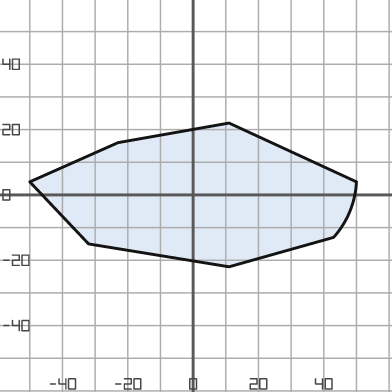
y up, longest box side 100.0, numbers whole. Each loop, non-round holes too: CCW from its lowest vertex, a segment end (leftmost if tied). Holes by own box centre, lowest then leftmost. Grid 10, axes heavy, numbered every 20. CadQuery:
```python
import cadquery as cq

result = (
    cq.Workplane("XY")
    .moveTo(11.0, -22.0)
    .lineTo(43.0, -13.0)
    .threePointArc((48.0, -5.0), (50.0, 4.0))
    .lineTo(11.0, 22.0)
    .lineTo(-23.0, 16.0)
    .lineTo(-50.0, 4.0)
    .lineTo(-32.0, -15.0)
    .close()
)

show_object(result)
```